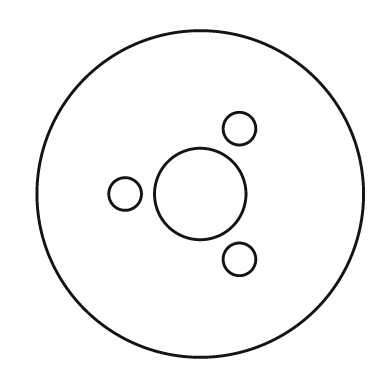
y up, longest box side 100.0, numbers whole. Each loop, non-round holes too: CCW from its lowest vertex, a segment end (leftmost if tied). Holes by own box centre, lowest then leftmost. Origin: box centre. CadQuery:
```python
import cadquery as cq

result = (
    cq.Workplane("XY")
    .moveTo(0.0, 0.0)
    .circle(50.0)
    .moveTo(12.0, -20.0)
    .circle(5.0)
    .moveTo(-23.0, 0.0)
    .circle(5.0)
    .moveTo(0.0, 0.0)
    .circle(14.0)
    .moveTo(12.0, 20.0)
    .circle(5.0)
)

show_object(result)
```